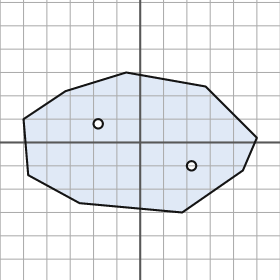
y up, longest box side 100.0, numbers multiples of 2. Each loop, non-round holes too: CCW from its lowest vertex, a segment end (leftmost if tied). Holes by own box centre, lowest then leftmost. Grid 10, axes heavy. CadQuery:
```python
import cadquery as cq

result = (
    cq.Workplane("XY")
    .moveTo(18.0, -30.0)
    .lineTo(44.0, -12.0)
    .lineTo(50.0, 2.0)
    .lineTo(28.0, 24.0)
    .lineTo(-6.0, 30.0)
    .lineTo(-32.0, 22.0)
    .lineTo(-50.0, 10.0)
    .lineTo(-48.0, -14.0)
    .lineTo(-26.0, -26.0)
    .close()
    .moveTo(22.0, -10.0)
    .circle(2.0)
    .moveTo(-18.0, 8.0)
    .circle(2.0)
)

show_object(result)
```